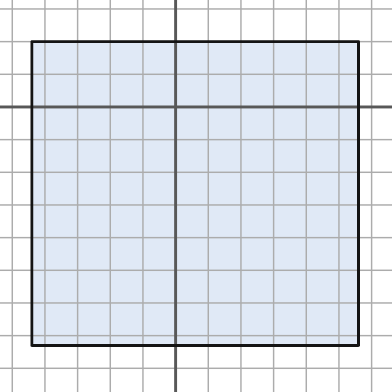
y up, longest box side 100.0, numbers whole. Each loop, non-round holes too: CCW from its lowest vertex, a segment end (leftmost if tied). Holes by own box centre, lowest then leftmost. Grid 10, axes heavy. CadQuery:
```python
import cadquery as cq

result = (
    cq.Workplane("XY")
    .moveTo(-44.0, -73.0)
    .lineTo(56.0, -73.0)
    .lineTo(56.0, 20.0)
    .lineTo(-44.0, 20.0)
    .close()
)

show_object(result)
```